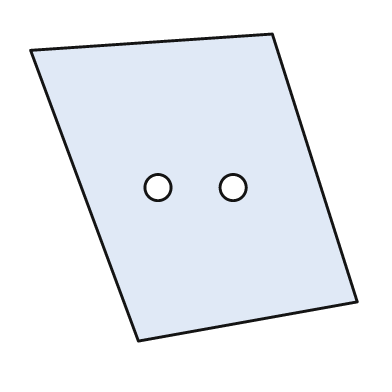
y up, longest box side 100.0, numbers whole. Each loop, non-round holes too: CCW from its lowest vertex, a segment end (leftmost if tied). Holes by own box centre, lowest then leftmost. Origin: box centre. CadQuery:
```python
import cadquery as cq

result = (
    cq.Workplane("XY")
    .moveTo(-17.0, -47.0)
    .lineTo(50.0, -35.0)
    .lineTo(24.0, 47.0)
    .lineTo(-50.0, 42.0)
    .close()
    .moveTo(-11.0, 0.0)
    .circle(4.0)
    .moveTo(12.0, 0.0)
    .circle(4.0)
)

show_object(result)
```